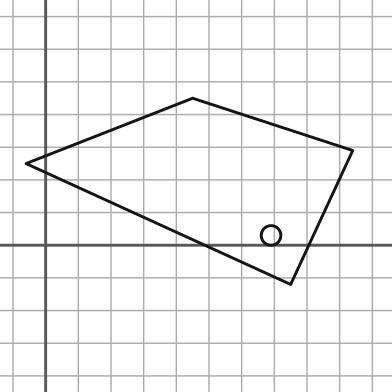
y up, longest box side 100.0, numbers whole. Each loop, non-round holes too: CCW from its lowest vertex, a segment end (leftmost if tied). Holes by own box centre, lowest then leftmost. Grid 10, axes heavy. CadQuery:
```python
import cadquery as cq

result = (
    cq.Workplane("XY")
    .moveTo(75.0, -12.0)
    .lineTo(94.0, 29.0)
    .lineTo(45.0, 45.0)
    .lineTo(-6.0, 25.0)
    .close()
    .moveTo(69.0, 3.0)
    .circle(3.0)
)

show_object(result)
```